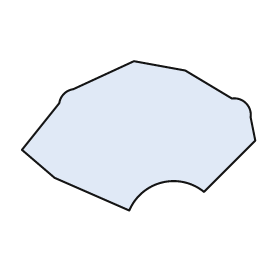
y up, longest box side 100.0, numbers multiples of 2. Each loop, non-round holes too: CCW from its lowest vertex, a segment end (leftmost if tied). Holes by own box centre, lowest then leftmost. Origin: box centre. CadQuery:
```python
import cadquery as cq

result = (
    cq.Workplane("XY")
    .moveTo(-4.0, -32.0)
    .threePointArc((10.0, -20.0), (28.0, -24.0))
    .lineTo(50.0, -2.0)
    .lineTo(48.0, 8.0)
    .threePointArc((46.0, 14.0), (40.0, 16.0))
    .lineTo(20.0, 28.0)
    .lineTo(-2.0, 32.0)
    .lineTo(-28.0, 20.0)
    .threePointArc((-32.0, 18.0), (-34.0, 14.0))
    .lineTo(-50.0, -6.0)
    .lineTo(-36.0, -18.0)
    .close()
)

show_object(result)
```